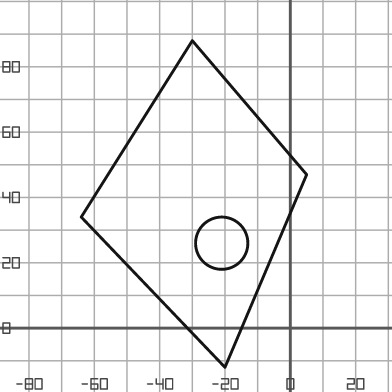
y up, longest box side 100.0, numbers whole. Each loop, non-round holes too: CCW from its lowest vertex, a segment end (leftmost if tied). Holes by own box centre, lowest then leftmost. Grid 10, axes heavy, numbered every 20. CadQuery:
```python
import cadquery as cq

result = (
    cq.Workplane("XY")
    .moveTo(-20.0, -12.0)
    .lineTo(5.0, 47.0)
    .lineTo(-30.0, 88.0)
    .lineTo(-64.0, 34.0)
    .close()
    .moveTo(-21.0, 26.0)
    .circle(8.0)
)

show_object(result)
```